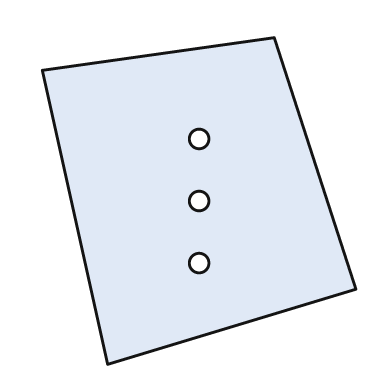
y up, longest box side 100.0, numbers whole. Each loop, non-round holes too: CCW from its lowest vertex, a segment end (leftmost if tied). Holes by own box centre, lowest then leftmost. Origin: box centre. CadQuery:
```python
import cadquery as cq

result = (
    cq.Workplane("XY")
    .moveTo(-28.0, -50.0)
    .lineTo(48.0, -27.0)
    .lineTo(23.0, 50.0)
    .lineTo(-48.0, 40.0)
    .close()
    .moveTo(0.0, -19.0)
    .circle(3.0)
    .moveTo(0.0, 0.0)
    .circle(3.0)
    .moveTo(0.0, 19.0)
    .circle(3.0)
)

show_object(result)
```